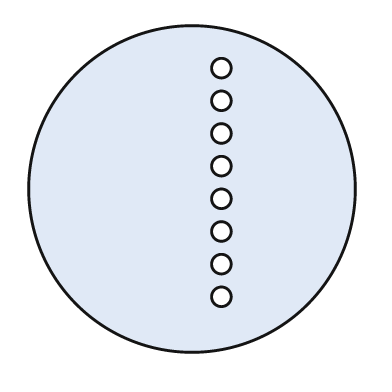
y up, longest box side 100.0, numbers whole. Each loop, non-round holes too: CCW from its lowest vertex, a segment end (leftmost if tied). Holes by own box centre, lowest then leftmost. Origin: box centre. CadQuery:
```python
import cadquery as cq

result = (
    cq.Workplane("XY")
    .moveTo(0.0, 0.0)
    .circle(50.0)
    .moveTo(9.0, -33.0)
    .circle(3.0)
    .moveTo(9.0, -23.0)
    .circle(3.0)
    .moveTo(9.0, -13.0)
    .circle(3.0)
    .moveTo(9.0, -3.0)
    .circle(3.0)
    .moveTo(9.0, 7.0)
    .circle(3.0)
    .moveTo(9.0, 17.0)
    .circle(3.0)
    .moveTo(9.0, 27.0)
    .circle(3.0)
    .moveTo(9.0, 37.0)
    .circle(3.0)
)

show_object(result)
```